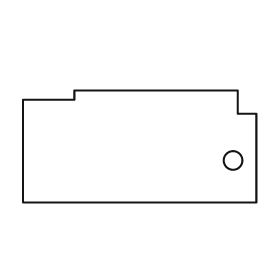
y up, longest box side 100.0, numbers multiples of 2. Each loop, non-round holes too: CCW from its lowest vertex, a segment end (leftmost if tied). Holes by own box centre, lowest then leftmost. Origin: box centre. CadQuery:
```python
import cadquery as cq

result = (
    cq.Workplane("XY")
    .moveTo(-50.0, -24.0)
    .lineTo(50.0, -24.0)
    .lineTo(50.0, 14.0)
    .lineTo(42.0, 14.0)
    .lineTo(42.0, 24.0)
    .lineTo(-28.0, 24.0)
    .lineTo(-28.0, 20.0)
    .lineTo(-50.0, 20.0)
    .close()
    .moveTo(40.0, -6.0)
    .circle(4.0)
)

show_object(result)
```